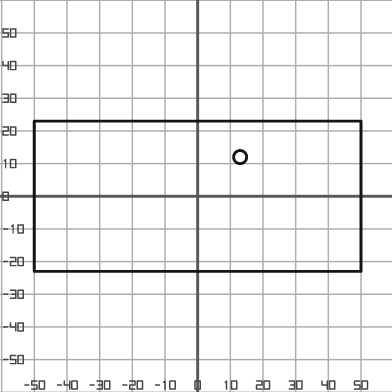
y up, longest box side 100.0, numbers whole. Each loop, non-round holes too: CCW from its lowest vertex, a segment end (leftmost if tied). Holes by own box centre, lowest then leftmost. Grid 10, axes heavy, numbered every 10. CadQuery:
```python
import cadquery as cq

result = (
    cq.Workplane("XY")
    .moveTo(-50.0, -23.0)
    .lineTo(50.0, -23.0)
    .lineTo(50.0, 23.0)
    .lineTo(-50.0, 23.0)
    .close()
    .moveTo(13.0, 12.0)
    .circle(2.0)
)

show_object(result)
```